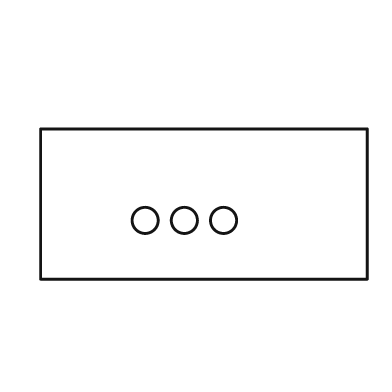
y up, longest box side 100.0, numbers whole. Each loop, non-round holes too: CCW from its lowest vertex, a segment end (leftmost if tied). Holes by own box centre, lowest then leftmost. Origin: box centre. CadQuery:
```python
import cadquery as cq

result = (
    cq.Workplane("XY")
    .moveTo(-50.0, -23.0)
    .lineTo(50.0, -23.0)
    .lineTo(50.0, 23.0)
    .lineTo(-50.0, 23.0)
    .close()
    .moveTo(-18.0, -5.0)
    .circle(4.0)
    .moveTo(-6.0, -5.0)
    .circle(4.0)
    .moveTo(6.0, -5.0)
    .circle(4.0)
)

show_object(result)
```